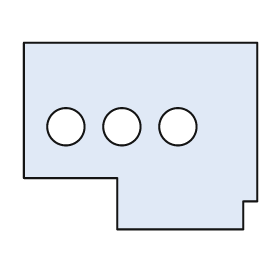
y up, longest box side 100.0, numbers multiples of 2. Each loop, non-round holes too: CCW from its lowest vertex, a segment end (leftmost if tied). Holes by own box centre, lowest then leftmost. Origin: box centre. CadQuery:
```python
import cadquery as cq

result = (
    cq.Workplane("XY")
    .moveTo(-10.0, -40.0)
    .lineTo(44.0, -40.0)
    .lineTo(44.0, -28.0)
    .lineTo(50.0, -28.0)
    .lineTo(50.0, 40.0)
    .lineTo(-50.0, 40.0)
    .lineTo(-50.0, -18.0)
    .lineTo(-10.0, -18.0)
    .close()
    .moveTo(-32.0, 4.0)
    .circle(8.0)
    .moveTo(-8.0, 4.0)
    .circle(8.0)
    .moveTo(16.0, 4.0)
    .circle(8.0)
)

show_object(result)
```